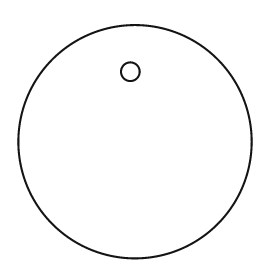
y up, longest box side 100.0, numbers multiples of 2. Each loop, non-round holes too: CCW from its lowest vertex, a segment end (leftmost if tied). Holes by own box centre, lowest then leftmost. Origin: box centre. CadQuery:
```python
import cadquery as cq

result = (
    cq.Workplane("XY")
    .moveTo(0.0, 0.0)
    .circle(50.0)
    .moveTo(-2.0, 30.0)
    .circle(4.0)
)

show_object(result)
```